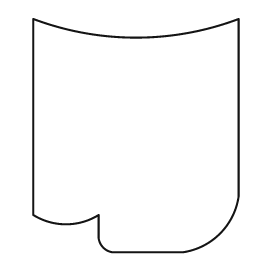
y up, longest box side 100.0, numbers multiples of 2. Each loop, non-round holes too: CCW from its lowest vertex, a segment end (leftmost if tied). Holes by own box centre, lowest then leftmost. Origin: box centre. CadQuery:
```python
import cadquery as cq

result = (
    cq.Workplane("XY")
    .moveTo(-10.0, -50.0)
    .lineTo(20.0, -50.0)
    .threePointArc((36.0, -42.0), (44.0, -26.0))
    .lineTo(44.0, 50.0)
    .threePointArc((0.0, 42.0), (-44.0, 50.0))
    .lineTo(-44.0, -34.0)
    .threePointArc((-30.0, -38.0), (-16.0, -34.0))
    .lineTo(-16.0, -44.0)
    .threePointArc((-14.0, -48.0), (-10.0, -50.0))
    .close()
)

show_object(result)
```